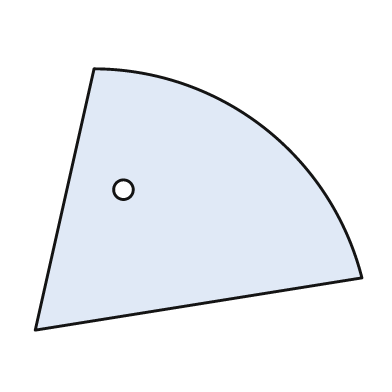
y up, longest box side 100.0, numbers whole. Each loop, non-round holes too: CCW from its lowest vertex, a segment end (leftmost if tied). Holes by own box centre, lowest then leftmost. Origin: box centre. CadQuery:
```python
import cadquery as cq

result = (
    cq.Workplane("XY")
    .moveTo(-50.0, -40.0)
    .lineTo(50.0, -24.0)
    .threePointArc((20.0, 22.0), (-32.0, 40.0))
    .close()
    .moveTo(-23.0, 3.0)
    .circle(3.0)
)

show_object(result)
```